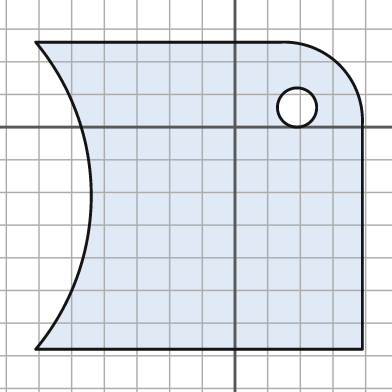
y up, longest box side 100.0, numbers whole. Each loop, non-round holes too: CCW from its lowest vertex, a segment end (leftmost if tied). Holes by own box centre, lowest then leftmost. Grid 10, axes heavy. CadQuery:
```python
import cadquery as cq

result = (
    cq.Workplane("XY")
    .moveTo(-61.0, -68.0)
    .lineTo(39.0, -68.0)
    .lineTo(39.0, 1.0)
    .threePointArc((32.0, 19.0), (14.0, 26.0))
    .lineTo(-61.0, 26.0)
    .threePointArc((-44.0, -21.0), (-61.0, -68.0))
    .close()
    .moveTo(19.0, 6.0)
    .circle(6.0)
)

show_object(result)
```